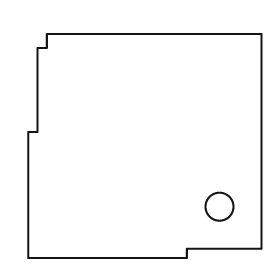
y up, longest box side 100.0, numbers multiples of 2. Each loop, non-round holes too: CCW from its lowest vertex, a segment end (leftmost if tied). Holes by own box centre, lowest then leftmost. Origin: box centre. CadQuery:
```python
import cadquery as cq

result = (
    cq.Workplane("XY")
    .moveTo(-50.0, -48.0)
    .lineTo(18.0, -48.0)
    .lineTo(18.0, -44.0)
    .lineTo(50.0, -44.0)
    .lineTo(50.0, 48.0)
    .lineTo(-42.0, 48.0)
    .lineTo(-42.0, 42.0)
    .lineTo(-46.0, 42.0)
    .lineTo(-46.0, 6.0)
    .lineTo(-50.0, 6.0)
    .close()
    .moveTo(32.0, -26.0)
    .circle(6.0)
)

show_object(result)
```